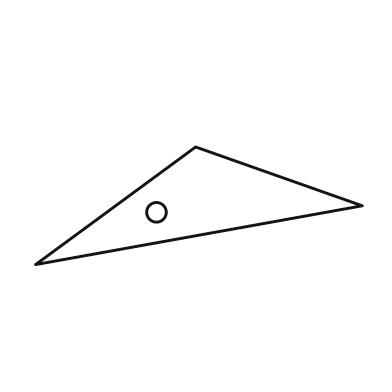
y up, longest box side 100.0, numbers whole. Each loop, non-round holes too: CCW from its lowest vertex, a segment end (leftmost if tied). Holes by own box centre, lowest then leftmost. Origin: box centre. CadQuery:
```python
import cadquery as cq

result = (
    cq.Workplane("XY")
    .moveTo(-50.0, -18.0)
    .lineTo(50.0, 0.0)
    .lineTo(-1.0, 18.0)
    .close()
    .moveTo(-13.0, -2.0)
    .circle(3.0)
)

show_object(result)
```